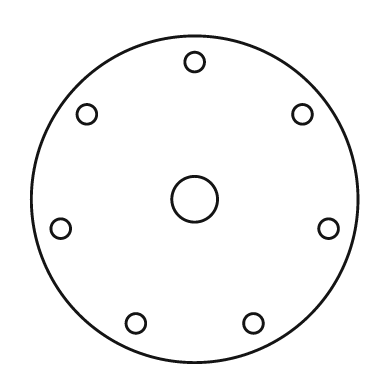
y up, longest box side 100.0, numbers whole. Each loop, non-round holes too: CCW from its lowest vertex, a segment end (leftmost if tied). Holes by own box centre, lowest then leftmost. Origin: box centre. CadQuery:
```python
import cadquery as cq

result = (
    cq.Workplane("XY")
    .moveTo(0.0, 0.0)
    .circle(50.0)
    .moveTo(-18.0, -38.0)
    .circle(3.0)
    .moveTo(18.0, -38.0)
    .circle(3.0)
    .moveTo(-41.0, -9.0)
    .circle(3.0)
    .moveTo(41.0, -9.0)
    .circle(3.0)
    .moveTo(0.0, 0.0)
    .circle(7.0)
    .moveTo(-33.0, 26.0)
    .circle(3.0)
    .moveTo(33.0, 26.0)
    .circle(3.0)
    .moveTo(0.0, 42.0)
    .circle(3.0)
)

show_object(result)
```